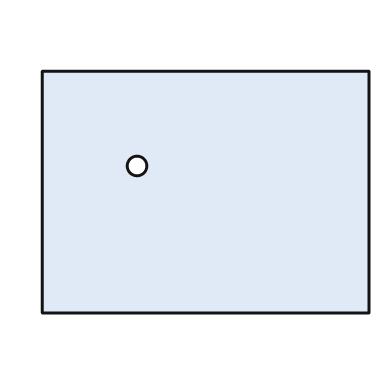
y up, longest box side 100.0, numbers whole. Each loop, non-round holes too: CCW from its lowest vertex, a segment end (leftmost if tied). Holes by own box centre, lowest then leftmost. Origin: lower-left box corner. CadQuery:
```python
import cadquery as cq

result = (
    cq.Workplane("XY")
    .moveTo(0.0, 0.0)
    .lineTo(100.0, 0.0)
    .lineTo(100.0, 74.0)
    .lineTo(0.0, 74.0)
    .close()
    .moveTo(29.0, 45.0)
    .circle(3.0)
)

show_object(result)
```